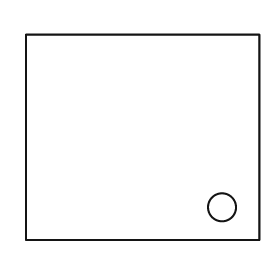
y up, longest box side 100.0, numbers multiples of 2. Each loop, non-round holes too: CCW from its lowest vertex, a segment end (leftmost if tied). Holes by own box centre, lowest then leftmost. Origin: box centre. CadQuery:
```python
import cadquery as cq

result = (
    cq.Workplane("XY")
    .moveTo(-50.0, -44.0)
    .lineTo(50.0, -44.0)
    .lineTo(50.0, 44.0)
    .lineTo(-50.0, 44.0)
    .close()
    .moveTo(34.0, -30.0)
    .circle(6.0)
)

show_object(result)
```